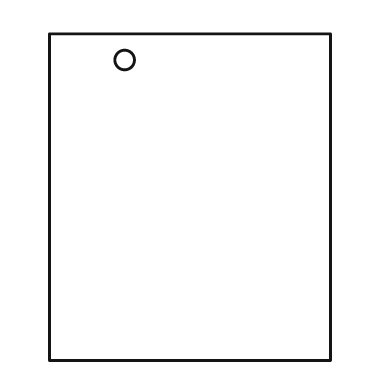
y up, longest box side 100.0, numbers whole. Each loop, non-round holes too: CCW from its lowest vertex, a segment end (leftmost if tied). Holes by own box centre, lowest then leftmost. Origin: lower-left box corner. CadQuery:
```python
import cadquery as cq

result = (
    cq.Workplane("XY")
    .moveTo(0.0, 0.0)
    .lineTo(86.0, 0.0)
    .lineTo(86.0, 100.0)
    .lineTo(0.0, 100.0)
    .close()
    .moveTo(23.0, 92.0)
    .circle(3.0)
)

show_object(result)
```